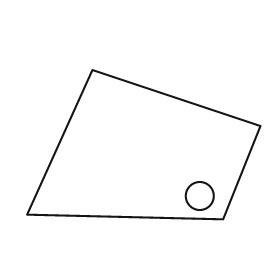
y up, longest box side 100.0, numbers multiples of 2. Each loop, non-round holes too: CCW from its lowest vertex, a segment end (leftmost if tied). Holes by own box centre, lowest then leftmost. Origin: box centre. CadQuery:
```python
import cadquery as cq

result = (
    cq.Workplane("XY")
    .moveTo(34.0, -32.0)
    .lineTo(50.0, 8.0)
    .lineTo(-22.0, 32.0)
    .lineTo(-50.0, -30.0)
    .close()
    .moveTo(24.0, -22.0)
    .circle(6.0)
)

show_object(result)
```